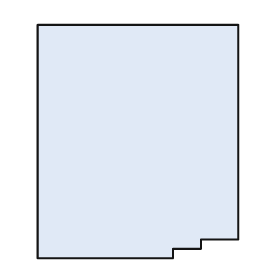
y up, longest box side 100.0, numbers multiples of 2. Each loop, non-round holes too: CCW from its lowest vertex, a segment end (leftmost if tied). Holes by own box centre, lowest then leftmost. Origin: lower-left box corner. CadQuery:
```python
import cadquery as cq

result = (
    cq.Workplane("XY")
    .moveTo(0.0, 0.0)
    .lineTo(58.0, 0.0)
    .lineTo(58.0, 4.0)
    .lineTo(70.0, 4.0)
    .lineTo(70.0, 8.0)
    .lineTo(86.0, 8.0)
    .lineTo(86.0, 100.0)
    .lineTo(0.0, 100.0)
    .close()
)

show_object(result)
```